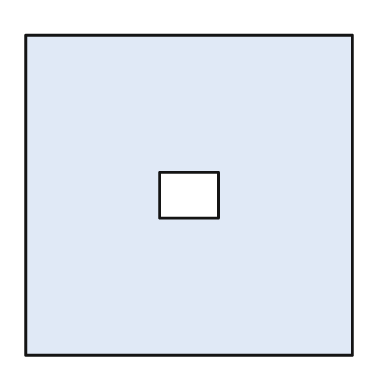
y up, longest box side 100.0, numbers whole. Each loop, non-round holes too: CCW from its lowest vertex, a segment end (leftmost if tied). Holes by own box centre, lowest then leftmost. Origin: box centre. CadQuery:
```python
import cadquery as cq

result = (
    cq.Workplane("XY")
    .moveTo(-50.0, -49.0)
    .lineTo(50.0, -49.0)
    .lineTo(50.0, 49.0)
    .lineTo(-50.0, 49.0)
    .close()
    .moveTo(-9.0, -7.0)
    .lineTo(9.0, -7.0)
    .lineTo(9.0, 7.0)
    .lineTo(-9.0, 7.0)
    .close()
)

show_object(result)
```